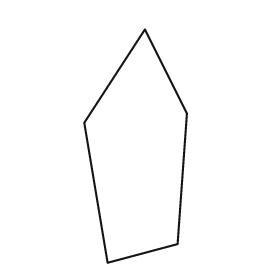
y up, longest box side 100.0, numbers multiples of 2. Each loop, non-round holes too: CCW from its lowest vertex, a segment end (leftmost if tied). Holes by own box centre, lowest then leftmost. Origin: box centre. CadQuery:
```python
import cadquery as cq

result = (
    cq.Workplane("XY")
    .moveTo(-12.0, -50.0)
    .lineTo(18.0, -42.0)
    .lineTo(22.0, 14.0)
    .lineTo(4.0, 50.0)
    .lineTo(-22.0, 10.0)
    .close()
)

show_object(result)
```